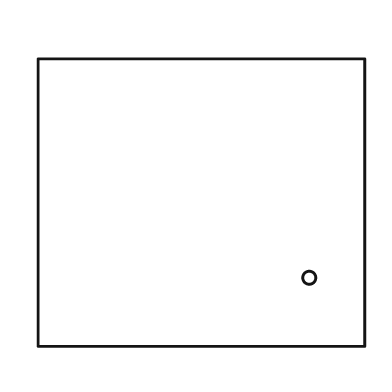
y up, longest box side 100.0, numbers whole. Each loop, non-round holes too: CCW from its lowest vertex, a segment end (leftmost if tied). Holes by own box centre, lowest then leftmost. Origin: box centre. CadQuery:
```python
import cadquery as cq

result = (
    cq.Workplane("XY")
    .moveTo(-50.0, -44.0)
    .lineTo(50.0, -44.0)
    .lineTo(50.0, 44.0)
    .lineTo(-50.0, 44.0)
    .close()
    .moveTo(33.0, -23.0)
    .circle(2.0)
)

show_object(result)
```